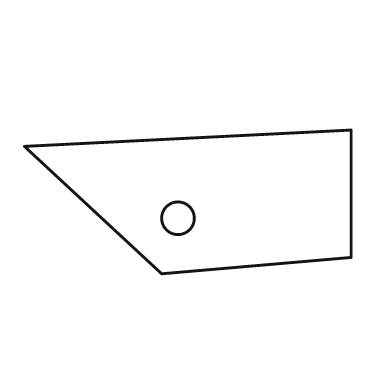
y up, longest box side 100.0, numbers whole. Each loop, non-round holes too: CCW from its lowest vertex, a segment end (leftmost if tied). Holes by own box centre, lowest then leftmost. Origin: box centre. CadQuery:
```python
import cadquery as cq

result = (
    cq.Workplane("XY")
    .moveTo(-8.0, -22.0)
    .lineTo(50.0, -17.0)
    .lineTo(50.0, 22.0)
    .lineTo(-50.0, 17.0)
    .close()
    .moveTo(-3.0, -5.0)
    .circle(5.0)
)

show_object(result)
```